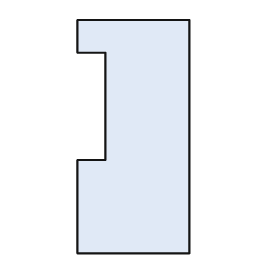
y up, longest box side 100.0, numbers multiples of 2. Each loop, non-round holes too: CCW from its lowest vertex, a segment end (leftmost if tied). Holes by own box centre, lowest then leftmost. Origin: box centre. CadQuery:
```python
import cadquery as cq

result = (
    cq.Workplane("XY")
    .moveTo(-24.0, -50.0)
    .lineTo(24.0, -50.0)
    .lineTo(24.0, 50.0)
    .lineTo(-24.0, 50.0)
    .lineTo(-24.0, 36.0)
    .lineTo(-12.0, 36.0)
    .lineTo(-12.0, -10.0)
    .lineTo(-24.0, -10.0)
    .close()
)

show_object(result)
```